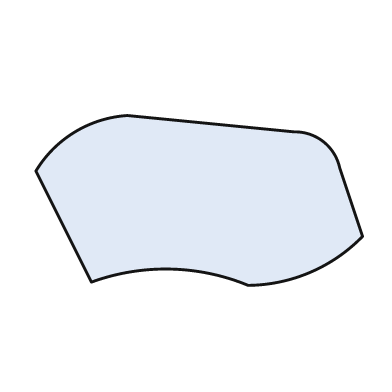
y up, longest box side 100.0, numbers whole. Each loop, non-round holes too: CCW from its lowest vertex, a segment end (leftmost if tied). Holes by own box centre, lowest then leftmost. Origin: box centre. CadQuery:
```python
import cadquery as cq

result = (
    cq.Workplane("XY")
    .moveTo(15.0, -26.0)
    .threePointArc((34.0, -22.0), (50.0, -11.0))
    .lineTo(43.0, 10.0)
    .threePointArc((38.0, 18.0), (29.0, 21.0))
    .lineTo(-22.0, 26.0)
    .threePointArc((-38.0, 21.0), (-50.0, 9.0))
    .lineTo(-33.0, -25.0)
    .threePointArc((-9.0, -21.0), (15.0, -26.0))
    .close()
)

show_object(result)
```